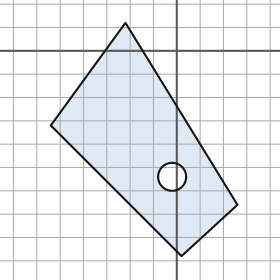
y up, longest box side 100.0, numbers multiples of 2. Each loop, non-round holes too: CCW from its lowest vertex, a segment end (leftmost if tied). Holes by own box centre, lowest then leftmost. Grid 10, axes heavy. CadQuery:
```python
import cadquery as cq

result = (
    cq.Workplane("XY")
    .moveTo(2.0, -88.0)
    .lineTo(26.0, -66.0)
    .lineTo(-22.0, 12.0)
    .lineTo(-54.0, -32.0)
    .close()
    .moveTo(-2.0, -54.0)
    .circle(6.0)
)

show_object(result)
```